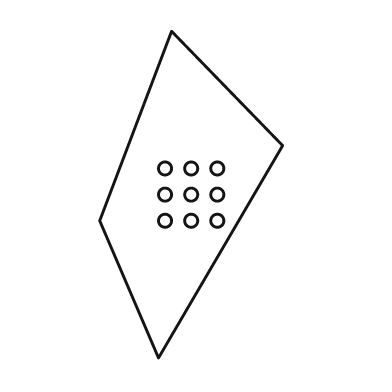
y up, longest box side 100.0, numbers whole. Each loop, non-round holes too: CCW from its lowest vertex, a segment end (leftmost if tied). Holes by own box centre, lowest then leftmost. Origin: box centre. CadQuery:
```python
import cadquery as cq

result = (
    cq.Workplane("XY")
    .moveTo(-10.0, -50.0)
    .lineTo(28.0, 15.0)
    .lineTo(-6.0, 50.0)
    .lineTo(-28.0, -8.0)
    .close()
    .moveTo(-8.0, -8.0)
    .circle(2.0)
    .moveTo(0.0, -8.0)
    .circle(2.0)
    .moveTo(8.0, -8.0)
    .circle(2.0)
    .moveTo(-8.0, 0.0)
    .circle(2.0)
    .moveTo(0.0, 0.0)
    .circle(2.0)
    .moveTo(8.0, 0.0)
    .circle(2.0)
    .moveTo(-8.0, 8.0)
    .circle(2.0)
    .moveTo(0.0, 8.0)
    .circle(2.0)
    .moveTo(8.0, 8.0)
    .circle(2.0)
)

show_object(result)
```